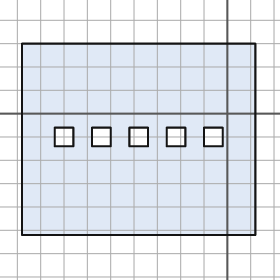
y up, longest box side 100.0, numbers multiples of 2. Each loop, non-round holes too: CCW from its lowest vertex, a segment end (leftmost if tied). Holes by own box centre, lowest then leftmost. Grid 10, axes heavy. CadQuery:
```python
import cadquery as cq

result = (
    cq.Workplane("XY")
    .moveTo(-88.0, -52.0)
    .lineTo(12.0, -52.0)
    .lineTo(12.0, 30.0)
    .lineTo(-88.0, 30.0)
    .close()
    .moveTo(-74.0, -14.0)
    .lineTo(-66.0, -14.0)
    .lineTo(-66.0, -6.0)
    .lineTo(-74.0, -6.0)
    .close()
    .moveTo(-58.0, -14.0)
    .lineTo(-50.0, -14.0)
    .lineTo(-50.0, -6.0)
    .lineTo(-58.0, -6.0)
    .close()
    .moveTo(-42.0, -14.0)
    .lineTo(-34.0, -14.0)
    .lineTo(-34.0, -6.0)
    .lineTo(-42.0, -6.0)
    .close()
    .moveTo(-26.0, -14.0)
    .lineTo(-18.0, -14.0)
    .lineTo(-18.0, -6.0)
    .lineTo(-26.0, -6.0)
    .close()
    .moveTo(-10.0, -14.0)
    .lineTo(-2.0, -14.0)
    .lineTo(-2.0, -6.0)
    .lineTo(-10.0, -6.0)
    .close()
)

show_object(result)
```